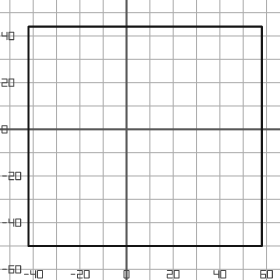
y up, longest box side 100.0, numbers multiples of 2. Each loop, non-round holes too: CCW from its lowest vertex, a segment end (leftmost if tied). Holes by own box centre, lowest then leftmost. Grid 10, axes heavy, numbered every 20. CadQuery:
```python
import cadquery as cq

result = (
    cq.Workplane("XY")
    .moveTo(-42.0, -50.0)
    .lineTo(58.0, -50.0)
    .lineTo(58.0, 44.0)
    .lineTo(-42.0, 44.0)
    .close()
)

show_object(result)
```